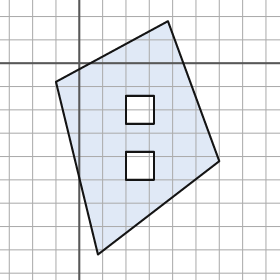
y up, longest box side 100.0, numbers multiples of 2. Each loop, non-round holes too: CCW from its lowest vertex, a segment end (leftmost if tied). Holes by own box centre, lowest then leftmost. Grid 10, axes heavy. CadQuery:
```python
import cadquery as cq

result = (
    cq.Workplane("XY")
    .moveTo(8.0, -82.0)
    .lineTo(60.0, -42.0)
    .lineTo(38.0, 18.0)
    .lineTo(-10.0, -8.0)
    .close()
    .moveTo(20.0, -50.0)
    .lineTo(32.0, -50.0)
    .lineTo(32.0, -38.0)
    .lineTo(20.0, -38.0)
    .close()
    .moveTo(20.0, -26.0)
    .lineTo(32.0, -26.0)
    .lineTo(32.0, -14.0)
    .lineTo(20.0, -14.0)
    .close()
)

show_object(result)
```